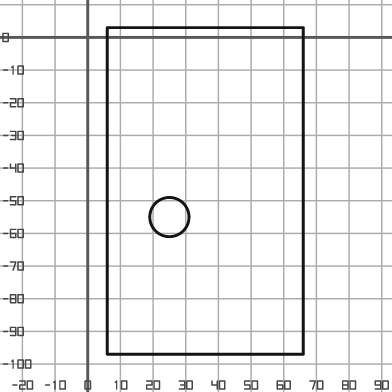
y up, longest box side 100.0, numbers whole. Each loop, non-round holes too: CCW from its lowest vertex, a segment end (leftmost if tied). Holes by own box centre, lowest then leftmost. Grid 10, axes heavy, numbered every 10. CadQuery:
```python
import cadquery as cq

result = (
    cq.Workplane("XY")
    .moveTo(6.0, -97.0)
    .lineTo(66.0, -97.0)
    .lineTo(66.0, 3.0)
    .lineTo(6.0, 3.0)
    .close()
    .moveTo(25.0, -55.0)
    .circle(6.0)
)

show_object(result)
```